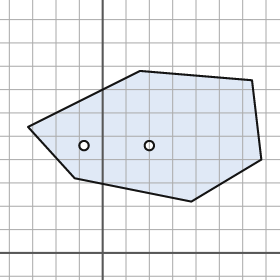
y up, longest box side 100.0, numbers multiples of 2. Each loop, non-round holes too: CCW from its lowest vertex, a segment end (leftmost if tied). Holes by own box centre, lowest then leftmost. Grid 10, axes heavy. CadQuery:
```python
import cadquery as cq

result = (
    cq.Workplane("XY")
    .moveTo(38.0, 22.0)
    .lineTo(68.0, 40.0)
    .lineTo(64.0, 74.0)
    .lineTo(16.0, 78.0)
    .lineTo(-32.0, 54.0)
    .lineTo(-12.0, 32.0)
    .close()
    .moveTo(-8.0, 46.0)
    .circle(2.0)
    .moveTo(20.0, 46.0)
    .circle(2.0)
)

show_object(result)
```